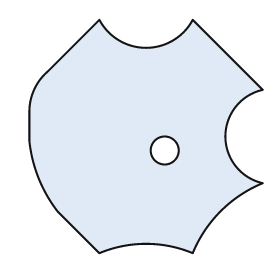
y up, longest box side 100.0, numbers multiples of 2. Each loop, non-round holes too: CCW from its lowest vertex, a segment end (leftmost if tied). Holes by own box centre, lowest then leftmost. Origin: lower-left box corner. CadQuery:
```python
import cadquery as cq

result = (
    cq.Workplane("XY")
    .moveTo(30.0, 0.0)
    .threePointArc((50.0, 4.0), (70.0, 0.0))
    .threePointArc((82.0, 18.0), (100.0, 30.0))
    .threePointArc((84.0, 50.0), (100.0, 70.0))
    .lineTo(70.0, 100.0)
    .threePointArc((50.0, 88.0), (30.0, 100.0))
    .lineTo(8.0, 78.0)
    .threePointArc((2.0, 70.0), (0.0, 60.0))
    .lineTo(0.0, 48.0)
    .threePointArc((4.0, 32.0), (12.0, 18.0))
    .close()
    .moveTo(58.0, 44.0)
    .circle(6.0)
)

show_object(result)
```